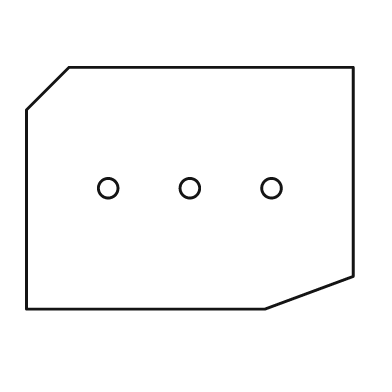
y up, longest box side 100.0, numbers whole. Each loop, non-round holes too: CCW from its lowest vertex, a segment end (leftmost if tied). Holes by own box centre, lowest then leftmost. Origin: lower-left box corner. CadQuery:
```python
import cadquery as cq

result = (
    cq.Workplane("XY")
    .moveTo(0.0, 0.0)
    .lineTo(73.0, 0.0)
    .lineTo(100.0, 10.0)
    .lineTo(100.0, 74.0)
    .lineTo(13.0, 74.0)
    .lineTo(0.0, 61.0)
    .close()
    .moveTo(25.0, 37.0)
    .circle(3.0)
    .moveTo(50.0, 37.0)
    .circle(3.0)
    .moveTo(75.0, 37.0)
    .circle(3.0)
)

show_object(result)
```